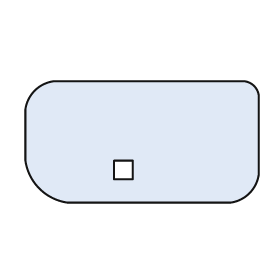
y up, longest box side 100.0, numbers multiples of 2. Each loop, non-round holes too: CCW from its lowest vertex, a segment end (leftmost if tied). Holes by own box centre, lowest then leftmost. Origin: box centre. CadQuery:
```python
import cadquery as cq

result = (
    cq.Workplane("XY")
    .moveTo(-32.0, -26.0)
    .lineTo(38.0, -26.0)
    .threePointArc((46.0, -22.0), (50.0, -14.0))
    .lineTo(50.0, 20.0)
    .threePointArc((48.0, 24.0), (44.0, 26.0))
    .lineTo(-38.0, 26.0)
    .threePointArc((-46.0, 22.0), (-50.0, 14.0))
    .lineTo(-50.0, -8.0)
    .threePointArc((-44.0, -20.0), (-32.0, -26.0))
    .close()
    .moveTo(-12.0, -16.0)
    .lineTo(-4.0, -16.0)
    .lineTo(-4.0, -8.0)
    .lineTo(-12.0, -8.0)
    .close()
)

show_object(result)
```